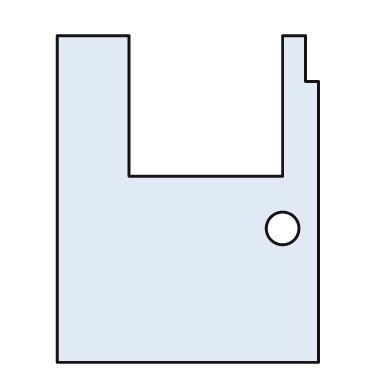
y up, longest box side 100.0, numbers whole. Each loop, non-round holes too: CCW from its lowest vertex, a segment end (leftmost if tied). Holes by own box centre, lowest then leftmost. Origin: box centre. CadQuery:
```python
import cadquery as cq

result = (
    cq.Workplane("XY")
    .moveTo(-40.0, -50.0)
    .lineTo(40.0, -50.0)
    .lineTo(40.0, 36.0)
    .lineTo(36.0, 36.0)
    .lineTo(36.0, 50.0)
    .lineTo(29.0, 50.0)
    .lineTo(29.0, 7.0)
    .lineTo(-18.0, 7.0)
    .lineTo(-18.0, 50.0)
    .lineTo(-40.0, 50.0)
    .close()
    .moveTo(29.0, -9.0)
    .circle(5.0)
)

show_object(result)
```